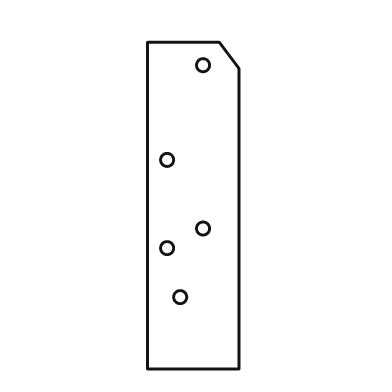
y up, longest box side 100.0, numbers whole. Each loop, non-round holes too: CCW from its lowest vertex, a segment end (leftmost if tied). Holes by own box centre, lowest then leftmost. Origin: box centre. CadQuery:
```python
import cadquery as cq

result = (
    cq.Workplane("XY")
    .moveTo(-14.0, -50.0)
    .lineTo(14.0, -50.0)
    .lineTo(14.0, 42.0)
    .lineTo(8.0, 50.0)
    .lineTo(-14.0, 50.0)
    .close()
    .moveTo(-4.0, -28.0)
    .circle(2.0)
    .moveTo(-8.0, -13.0)
    .circle(2.0)
    .moveTo(3.0, -7.0)
    .circle(2.0)
    .moveTo(-8.0, 14.0)
    .circle(2.0)
    .moveTo(3.0, 43.0)
    .circle(2.0)
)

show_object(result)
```